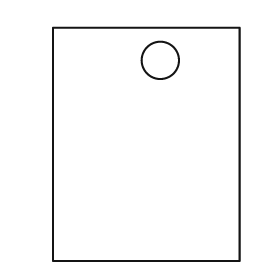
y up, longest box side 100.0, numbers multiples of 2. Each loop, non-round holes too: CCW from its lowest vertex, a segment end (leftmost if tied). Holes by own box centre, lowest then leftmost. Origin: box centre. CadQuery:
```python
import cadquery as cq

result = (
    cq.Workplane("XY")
    .moveTo(-40.0, -50.0)
    .lineTo(40.0, -50.0)
    .lineTo(40.0, 50.0)
    .lineTo(-40.0, 50.0)
    .close()
    .moveTo(6.0, 36.0)
    .circle(8.0)
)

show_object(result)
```